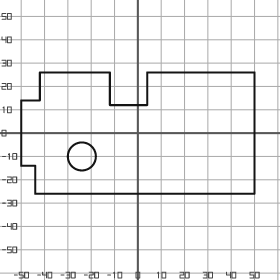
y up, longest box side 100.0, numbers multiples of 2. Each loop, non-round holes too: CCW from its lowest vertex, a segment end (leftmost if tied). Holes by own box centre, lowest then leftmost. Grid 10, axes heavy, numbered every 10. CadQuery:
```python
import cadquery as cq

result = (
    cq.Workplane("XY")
    .moveTo(-44.0, -26.0)
    .lineTo(50.0, -26.0)
    .lineTo(50.0, 26.0)
    .lineTo(4.0, 26.0)
    .lineTo(4.0, 12.0)
    .lineTo(-12.0, 12.0)
    .lineTo(-12.0, 26.0)
    .lineTo(-42.0, 26.0)
    .lineTo(-42.0, 14.0)
    .lineTo(-50.0, 14.0)
    .lineTo(-50.0, -14.0)
    .lineTo(-44.0, -14.0)
    .close()
    .moveTo(-24.0, -10.0)
    .circle(6.0)
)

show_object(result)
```